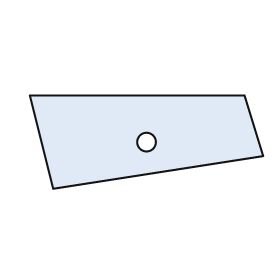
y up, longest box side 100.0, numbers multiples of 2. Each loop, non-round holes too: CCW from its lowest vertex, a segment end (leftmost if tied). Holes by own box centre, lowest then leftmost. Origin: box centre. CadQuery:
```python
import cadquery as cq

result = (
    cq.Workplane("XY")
    .moveTo(-40.0, -20.0)
    .lineTo(50.0, -6.0)
    .lineTo(42.0, 20.0)
    .lineTo(-50.0, 20.0)
    .close()
    .moveTo(0.0, 0.0)
    .circle(4.0)
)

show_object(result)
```